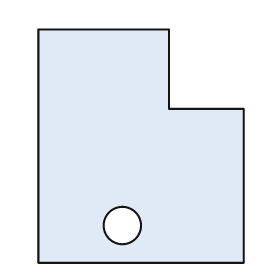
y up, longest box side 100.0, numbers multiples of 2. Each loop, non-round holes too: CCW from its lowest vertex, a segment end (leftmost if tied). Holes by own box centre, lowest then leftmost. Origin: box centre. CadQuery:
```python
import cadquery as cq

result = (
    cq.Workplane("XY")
    .moveTo(-44.0, -50.0)
    .lineTo(44.0, -50.0)
    .lineTo(44.0, 16.0)
    .lineTo(12.0, 16.0)
    .lineTo(12.0, 50.0)
    .lineTo(-44.0, 50.0)
    .close()
    .moveTo(-8.0, -34.0)
    .circle(8.0)
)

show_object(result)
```